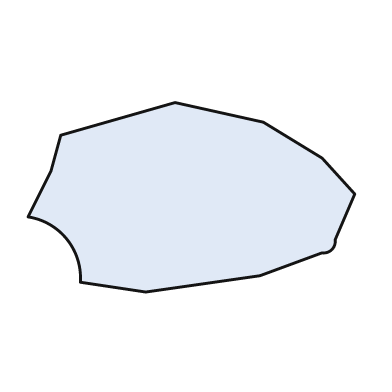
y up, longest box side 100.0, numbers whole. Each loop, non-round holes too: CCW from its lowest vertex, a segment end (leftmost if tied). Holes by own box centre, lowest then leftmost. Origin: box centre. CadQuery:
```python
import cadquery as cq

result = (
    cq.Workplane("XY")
    .moveTo(-14.0, -29.0)
    .lineTo(21.0, -24.0)
    .lineTo(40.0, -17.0)
    .threePointArc((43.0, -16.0), (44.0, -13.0))
    .lineTo(50.0, 1.0)
    .lineTo(40.0, 12.0)
    .lineTo(22.0, 23.0)
    .lineTo(-5.0, 29.0)
    .lineTo(-40.0, 19.0)
    .lineTo(-43.0, 8.0)
    .lineTo(-50.0, -6.0)
    .threePointArc((-38.0, -13.0), (-34.0, -26.0))
    .close()
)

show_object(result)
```